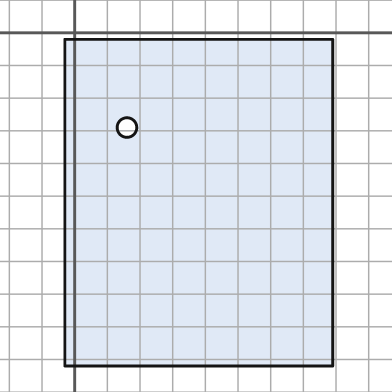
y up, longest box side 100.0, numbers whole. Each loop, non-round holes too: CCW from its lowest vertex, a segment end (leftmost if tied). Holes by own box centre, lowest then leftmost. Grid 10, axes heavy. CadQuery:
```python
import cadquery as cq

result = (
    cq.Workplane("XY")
    .moveTo(-3.0, -102.0)
    .lineTo(79.0, -102.0)
    .lineTo(79.0, -2.0)
    .lineTo(-3.0, -2.0)
    .close()
    .moveTo(16.0, -29.0)
    .circle(3.0)
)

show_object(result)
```